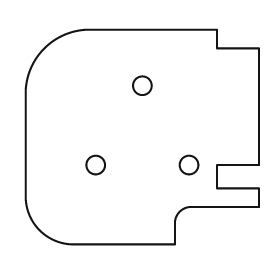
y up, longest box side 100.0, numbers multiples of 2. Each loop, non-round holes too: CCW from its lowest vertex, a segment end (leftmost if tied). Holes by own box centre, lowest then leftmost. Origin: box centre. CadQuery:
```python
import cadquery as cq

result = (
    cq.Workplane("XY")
    .moveTo(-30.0, -46.0)
    .lineTo(14.0, -46.0)
    .lineTo(14.0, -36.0)
    .threePointArc((16.0, -32.0), (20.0, -30.0))
    .lineTo(50.0, -30.0)
    .lineTo(50.0, -22.0)
    .lineTo(32.0, -22.0)
    .lineTo(32.0, -12.0)
    .lineTo(50.0, -12.0)
    .lineTo(50.0, 38.0)
    .lineTo(32.0, 38.0)
    .lineTo(32.0, 46.0)
    .lineTo(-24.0, 46.0)
    .threePointArc((-42.0, 38.0), (-50.0, 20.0))
    .lineTo(-50.0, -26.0)
    .threePointArc((-44.0, -40.0), (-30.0, -46.0))
    .close()
    .moveTo(-20.0, -12.0)
    .circle(4.0)
    .moveTo(20.0, -12.0)
    .circle(4.0)
    .moveTo(0.0, 22.0)
    .circle(4.0)
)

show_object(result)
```